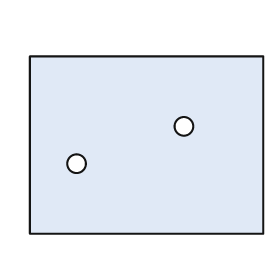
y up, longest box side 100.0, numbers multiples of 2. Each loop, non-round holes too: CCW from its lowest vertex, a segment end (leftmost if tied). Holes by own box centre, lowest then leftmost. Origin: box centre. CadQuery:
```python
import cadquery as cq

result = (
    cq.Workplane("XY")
    .moveTo(-50.0, -38.0)
    .lineTo(50.0, -38.0)
    .lineTo(50.0, 38.0)
    .lineTo(-50.0, 38.0)
    .close()
    .moveTo(-30.0, -8.0)
    .circle(4.0)
    .moveTo(16.0, 8.0)
    .circle(4.0)
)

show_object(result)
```